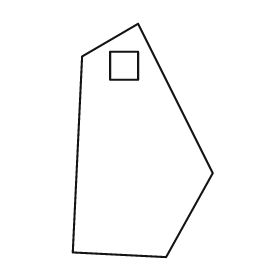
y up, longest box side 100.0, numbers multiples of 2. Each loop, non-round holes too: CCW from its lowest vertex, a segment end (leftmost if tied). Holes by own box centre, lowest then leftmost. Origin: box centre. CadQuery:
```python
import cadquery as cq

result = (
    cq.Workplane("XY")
    .moveTo(10.0, -50.0)
    .lineTo(30.0, -14.0)
    .lineTo(-2.0, 50.0)
    .lineTo(-26.0, 36.0)
    .lineTo(-30.0, -48.0)
    .close()
    .moveTo(-14.0, 26.0)
    .lineTo(-2.0, 26.0)
    .lineTo(-2.0, 38.0)
    .lineTo(-14.0, 38.0)
    .close()
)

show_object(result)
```